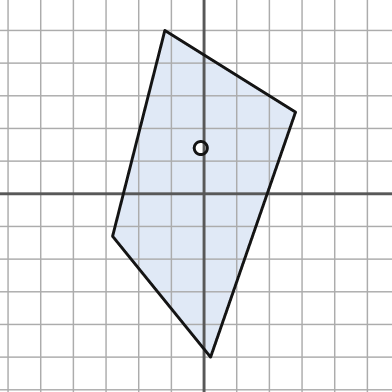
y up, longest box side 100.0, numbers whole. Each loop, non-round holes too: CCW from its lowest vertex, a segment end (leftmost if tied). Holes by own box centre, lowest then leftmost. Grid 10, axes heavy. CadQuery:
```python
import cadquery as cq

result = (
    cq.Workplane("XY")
    .moveTo(2.0, -50.0)
    .lineTo(28.0, 25.0)
    .lineTo(-12.0, 50.0)
    .lineTo(-28.0, -13.0)
    .close()
    .moveTo(-1.0, 14.0)
    .circle(2.0)
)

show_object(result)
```